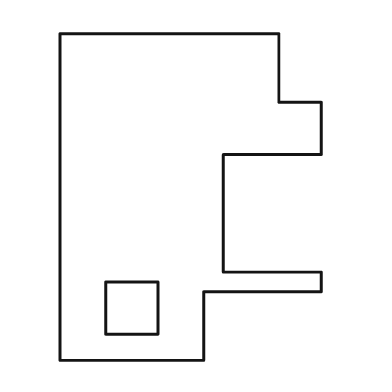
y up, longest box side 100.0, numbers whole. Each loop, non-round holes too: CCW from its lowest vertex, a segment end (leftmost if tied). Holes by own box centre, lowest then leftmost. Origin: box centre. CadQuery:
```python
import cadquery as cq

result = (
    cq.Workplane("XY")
    .moveTo(-40.0, -50.0)
    .lineTo(4.0, -50.0)
    .lineTo(4.0, -29.0)
    .lineTo(40.0, -29.0)
    .lineTo(40.0, -23.0)
    .lineTo(10.0, -23.0)
    .lineTo(10.0, 13.0)
    .lineTo(40.0, 13.0)
    .lineTo(40.0, 29.0)
    .lineTo(27.0, 29.0)
    .lineTo(27.0, 50.0)
    .lineTo(-40.0, 50.0)
    .close()
    .moveTo(-26.0, -42.0)
    .lineTo(-10.0, -42.0)
    .lineTo(-10.0, -26.0)
    .lineTo(-26.0, -26.0)
    .close()
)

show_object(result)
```